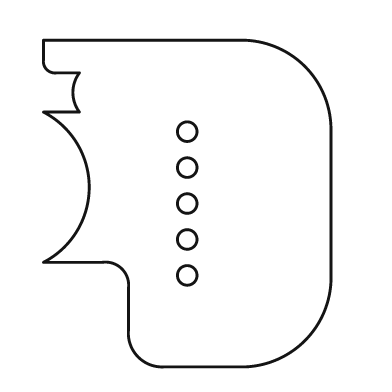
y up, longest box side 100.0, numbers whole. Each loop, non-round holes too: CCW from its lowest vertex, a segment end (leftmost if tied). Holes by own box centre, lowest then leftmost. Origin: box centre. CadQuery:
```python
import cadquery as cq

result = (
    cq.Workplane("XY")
    .moveTo(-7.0, -50.0)
    .lineTo(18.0, -50.0)
    .threePointArc((36.0, -42.0), (44.0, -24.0))
    .lineTo(44.0, 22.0)
    .threePointArc((36.0, 42.0), (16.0, 50.0))
    .lineTo(-44.0, 50.0)
    .lineTo(-44.0, 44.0)
    .threePointArc((-43.0, 41.0), (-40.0, 40.0))
    .lineTo(-33.0, 40.0)
    .threePointArc((-35.0, 34.0), (-33.0, 28.0))
    .lineTo(-44.0, 28.0)
    .threePointArc((-30.0, 5.0), (-44.0, -18.0))
    .lineTo(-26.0, -18.0)
    .threePointArc((-20.0, -20.0), (-18.0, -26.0))
    .lineTo(-18.0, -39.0)
    .threePointArc((-15.0, -47.0), (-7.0, -50.0))
    .close()
    .moveTo(0.0, -22.0)
    .circle(3.0)
    .moveTo(0.0, -11.0)
    .circle(3.0)
    .moveTo(0.0, 0.0)
    .circle(3.0)
    .moveTo(0.0, 11.0)
    .circle(3.0)
    .moveTo(0.0, 22.0)
    .circle(3.0)
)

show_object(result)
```